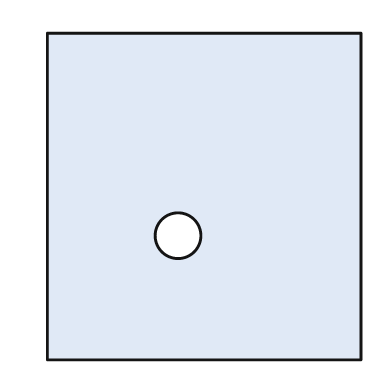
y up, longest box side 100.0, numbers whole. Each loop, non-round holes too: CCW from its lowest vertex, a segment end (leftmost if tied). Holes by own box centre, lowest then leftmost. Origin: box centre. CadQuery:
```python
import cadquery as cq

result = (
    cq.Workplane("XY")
    .moveTo(-48.0, -50.0)
    .lineTo(48.0, -50.0)
    .lineTo(48.0, 50.0)
    .lineTo(-48.0, 50.0)
    .close()
    .moveTo(-8.0, -12.0)
    .circle(7.0)
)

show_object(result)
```